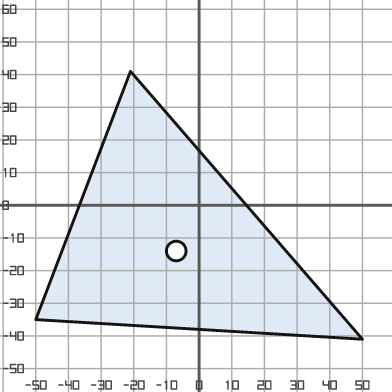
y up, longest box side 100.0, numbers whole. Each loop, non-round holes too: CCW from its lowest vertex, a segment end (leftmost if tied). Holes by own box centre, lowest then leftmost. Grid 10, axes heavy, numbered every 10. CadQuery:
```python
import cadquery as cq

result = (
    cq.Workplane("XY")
    .moveTo(50.0, -41.0)
    .lineTo(-21.0, 41.0)
    .lineTo(-50.0, -35.0)
    .close()
    .moveTo(-7.0, -14.0)
    .circle(3.0)
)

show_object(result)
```